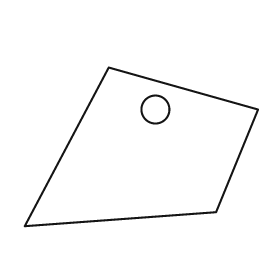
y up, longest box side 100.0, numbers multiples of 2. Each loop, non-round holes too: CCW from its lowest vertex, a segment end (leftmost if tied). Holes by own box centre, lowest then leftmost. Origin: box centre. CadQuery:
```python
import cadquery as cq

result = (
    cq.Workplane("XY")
    .moveTo(-50.0, -34.0)
    .lineTo(32.0, -28.0)
    .lineTo(50.0, 16.0)
    .lineTo(-14.0, 34.0)
    .close()
    .moveTo(6.0, 16.0)
    .circle(6.0)
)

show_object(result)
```